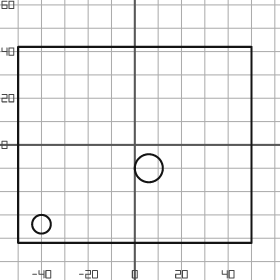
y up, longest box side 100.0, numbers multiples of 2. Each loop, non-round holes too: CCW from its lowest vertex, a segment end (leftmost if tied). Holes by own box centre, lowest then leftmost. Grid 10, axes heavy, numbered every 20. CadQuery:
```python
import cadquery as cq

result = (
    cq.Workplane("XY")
    .moveTo(-50.0, -42.0)
    .lineTo(50.0, -42.0)
    .lineTo(50.0, 42.0)
    .lineTo(-50.0, 42.0)
    .close()
    .moveTo(-40.0, -34.0)
    .circle(4.0)
    .moveTo(6.0, -10.0)
    .circle(6.0)
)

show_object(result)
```